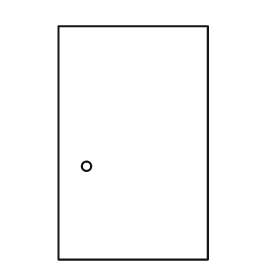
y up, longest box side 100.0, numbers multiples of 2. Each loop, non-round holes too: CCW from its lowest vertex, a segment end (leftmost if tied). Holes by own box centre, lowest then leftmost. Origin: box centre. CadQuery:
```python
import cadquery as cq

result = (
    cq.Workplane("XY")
    .moveTo(-32.0, -50.0)
    .lineTo(32.0, -50.0)
    .lineTo(32.0, 50.0)
    .lineTo(-32.0, 50.0)
    .close()
    .moveTo(-20.0, -10.0)
    .circle(2.0)
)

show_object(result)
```